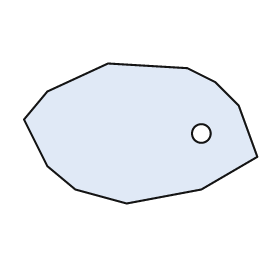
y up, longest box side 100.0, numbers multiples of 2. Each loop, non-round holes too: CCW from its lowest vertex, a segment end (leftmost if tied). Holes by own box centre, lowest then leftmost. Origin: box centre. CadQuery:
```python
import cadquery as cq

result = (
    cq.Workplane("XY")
    .moveTo(-6.0, -30.0)
    .lineTo(26.0, -24.0)
    .lineTo(50.0, -10.0)
    .lineTo(42.0, 12.0)
    .lineTo(32.0, 22.0)
    .lineTo(20.0, 28.0)
    .lineTo(-14.0, 30.0)
    .lineTo(-40.0, 18.0)
    .lineTo(-50.0, 6.0)
    .lineTo(-40.0, -14.0)
    .lineTo(-28.0, -24.0)
    .close()
    .moveTo(26.0, 0.0)
    .circle(4.0)
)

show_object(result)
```